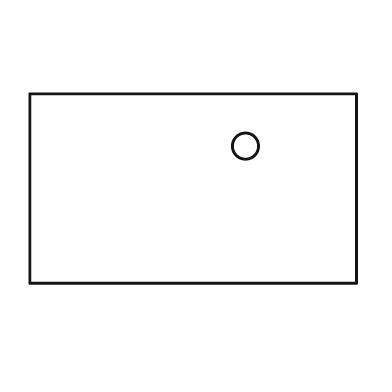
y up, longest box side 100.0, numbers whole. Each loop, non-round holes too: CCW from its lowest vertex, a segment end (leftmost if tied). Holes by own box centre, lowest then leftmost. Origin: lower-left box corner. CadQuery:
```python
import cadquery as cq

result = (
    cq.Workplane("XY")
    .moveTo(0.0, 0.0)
    .lineTo(100.0, 0.0)
    .lineTo(100.0, 58.0)
    .lineTo(0.0, 58.0)
    .close()
    .moveTo(66.0, 42.0)
    .circle(4.0)
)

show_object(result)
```